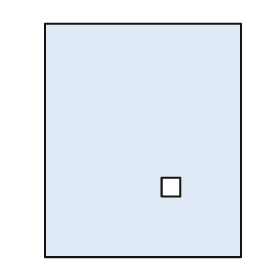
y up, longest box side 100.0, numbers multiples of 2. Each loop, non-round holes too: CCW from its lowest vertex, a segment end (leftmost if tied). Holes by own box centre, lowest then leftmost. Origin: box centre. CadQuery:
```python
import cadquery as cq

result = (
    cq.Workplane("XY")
    .moveTo(-42.0, -50.0)
    .lineTo(42.0, -50.0)
    .lineTo(42.0, 50.0)
    .lineTo(-42.0, 50.0)
    .close()
    .moveTo(8.0, -24.0)
    .lineTo(16.0, -24.0)
    .lineTo(16.0, -16.0)
    .lineTo(8.0, -16.0)
    .close()
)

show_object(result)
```